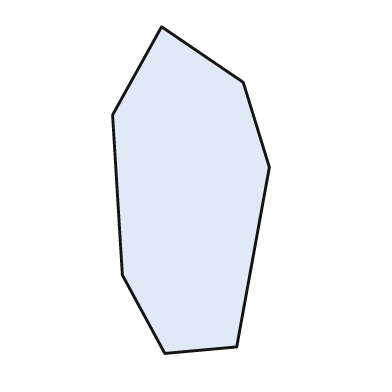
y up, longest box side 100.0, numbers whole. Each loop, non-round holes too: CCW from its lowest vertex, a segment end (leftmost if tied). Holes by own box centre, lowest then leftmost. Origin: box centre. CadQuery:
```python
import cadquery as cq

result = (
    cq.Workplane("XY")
    .moveTo(-8.0, -50.0)
    .lineTo(14.0, -48.0)
    .lineTo(24.0, 7.0)
    .lineTo(16.0, 33.0)
    .lineTo(-9.0, 50.0)
    .lineTo(-24.0, 23.0)
    .lineTo(-21.0, -26.0)
    .close()
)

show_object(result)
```